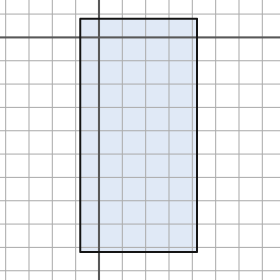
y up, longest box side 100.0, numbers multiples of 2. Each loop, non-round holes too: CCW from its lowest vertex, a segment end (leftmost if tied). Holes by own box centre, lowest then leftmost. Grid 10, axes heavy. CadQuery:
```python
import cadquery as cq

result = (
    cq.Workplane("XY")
    .moveTo(-8.0, -92.0)
    .lineTo(42.0, -92.0)
    .lineTo(42.0, 8.0)
    .lineTo(-8.0, 8.0)
    .close()
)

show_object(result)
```